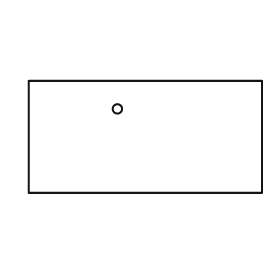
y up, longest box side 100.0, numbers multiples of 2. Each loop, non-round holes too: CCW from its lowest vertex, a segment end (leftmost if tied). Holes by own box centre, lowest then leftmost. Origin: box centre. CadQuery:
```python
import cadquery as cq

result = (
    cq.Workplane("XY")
    .moveTo(-50.0, -24.0)
    .lineTo(50.0, -24.0)
    .lineTo(50.0, 24.0)
    .lineTo(-50.0, 24.0)
    .close()
    .moveTo(-12.0, 12.0)
    .circle(2.0)
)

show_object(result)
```